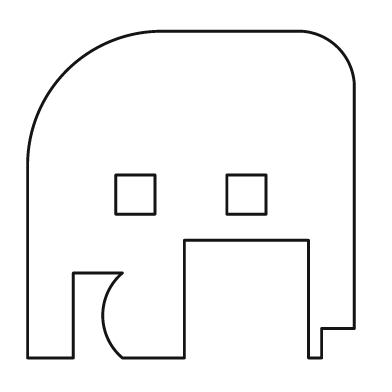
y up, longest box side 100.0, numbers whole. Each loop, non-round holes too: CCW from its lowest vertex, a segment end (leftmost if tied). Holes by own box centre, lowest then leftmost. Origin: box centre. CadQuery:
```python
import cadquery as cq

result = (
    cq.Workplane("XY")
    .moveTo(-50.0, -50.0)
    .lineTo(-36.0, -50.0)
    .lineTo(-36.0, -24.0)
    .lineTo(-21.0, -24.0)
    .threePointArc((-27.0, -37.0), (-21.0, -50.0))
    .lineTo(-2.0, -50.0)
    .lineTo(-2.0, -14.0)
    .lineTo(36.0, -14.0)
    .lineTo(36.0, -50.0)
    .lineTo(40.0, -50.0)
    .lineTo(40.0, -41.0)
    .lineTo(50.0, -41.0)
    .lineTo(50.0, 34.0)
    .threePointArc((45.0, 45.0), (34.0, 50.0))
    .lineTo(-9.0, 50.0)
    .threePointArc((-38.0, 38.0), (-50.0, 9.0))
    .close()
    .moveTo(-23.0, -6.0)
    .lineTo(-11.0, -6.0)
    .lineTo(-11.0, 6.0)
    .lineTo(-23.0, 6.0)
    .close()
    .moveTo(11.0, -6.0)
    .lineTo(23.0, -6.0)
    .lineTo(23.0, 6.0)
    .lineTo(11.0, 6.0)
    .close()
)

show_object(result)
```